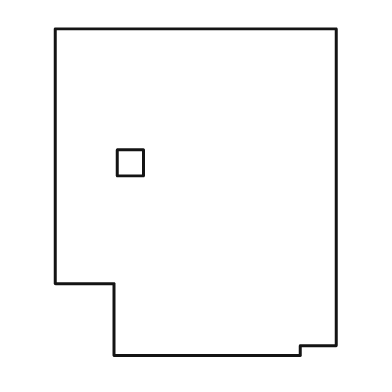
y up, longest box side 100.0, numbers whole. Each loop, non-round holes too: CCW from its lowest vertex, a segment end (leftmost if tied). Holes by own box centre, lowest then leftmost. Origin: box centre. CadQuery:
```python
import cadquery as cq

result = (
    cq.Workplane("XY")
    .moveTo(-25.0, -50.0)
    .lineTo(32.0, -50.0)
    .lineTo(32.0, -47.0)
    .lineTo(43.0, -47.0)
    .lineTo(43.0, 50.0)
    .lineTo(-43.0, 50.0)
    .lineTo(-43.0, -28.0)
    .lineTo(-25.0, -28.0)
    .close()
    .moveTo(-24.0, 5.0)
    .lineTo(-16.0, 5.0)
    .lineTo(-16.0, 13.0)
    .lineTo(-24.0, 13.0)
    .close()
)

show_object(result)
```